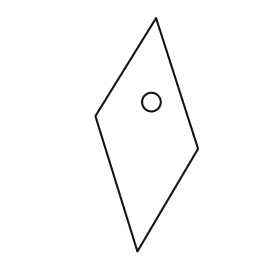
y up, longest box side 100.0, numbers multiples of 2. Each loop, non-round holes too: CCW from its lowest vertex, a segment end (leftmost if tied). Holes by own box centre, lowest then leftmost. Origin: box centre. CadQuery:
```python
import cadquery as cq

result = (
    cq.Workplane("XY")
    .moveTo(-4.0, -50.0)
    .lineTo(22.0, -6.0)
    .lineTo(4.0, 50.0)
    .lineTo(-22.0, 8.0)
    .close()
    .moveTo(2.0, 14.0)
    .circle(4.0)
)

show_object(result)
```